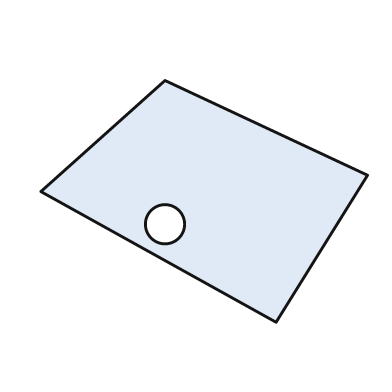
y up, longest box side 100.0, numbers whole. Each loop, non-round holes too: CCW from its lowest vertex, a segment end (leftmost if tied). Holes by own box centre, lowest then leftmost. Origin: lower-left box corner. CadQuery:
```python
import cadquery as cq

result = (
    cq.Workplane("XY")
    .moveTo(72.0, 0.0)
    .lineTo(100.0, 45.0)
    .lineTo(38.0, 74.0)
    .lineTo(0.0, 40.0)
    .close()
    .moveTo(38.0, 30.0)
    .circle(6.0)
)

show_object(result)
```